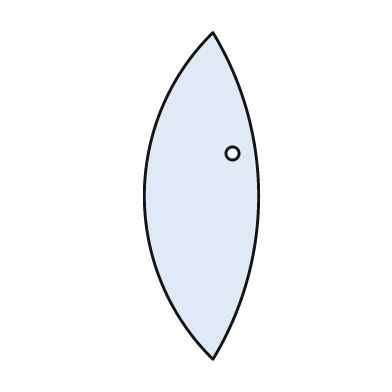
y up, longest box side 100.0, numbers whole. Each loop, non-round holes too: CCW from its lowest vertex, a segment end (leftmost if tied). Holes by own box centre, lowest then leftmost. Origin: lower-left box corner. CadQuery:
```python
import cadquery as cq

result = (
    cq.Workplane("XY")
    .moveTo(21.0, 0.0)
    .threePointArc((35.0, 50.0), (21.0, 100.0))
    .threePointArc((0.0, 50.0), (21.0, 0.0))
    .close()
    .moveTo(27.0, 63.0)
    .circle(2.0)
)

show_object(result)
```